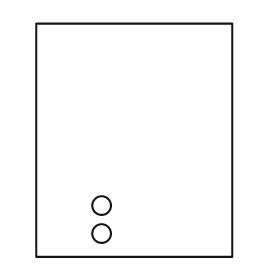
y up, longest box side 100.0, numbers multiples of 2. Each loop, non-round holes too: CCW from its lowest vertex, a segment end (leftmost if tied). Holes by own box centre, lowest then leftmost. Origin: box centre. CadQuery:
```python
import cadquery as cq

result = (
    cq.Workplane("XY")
    .moveTo(-42.0, -50.0)
    .lineTo(42.0, -50.0)
    .lineTo(42.0, 50.0)
    .lineTo(-42.0, 50.0)
    .close()
    .moveTo(-14.0, -40.0)
    .circle(4.0)
    .moveTo(-14.0, -28.0)
    .circle(4.0)
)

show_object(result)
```